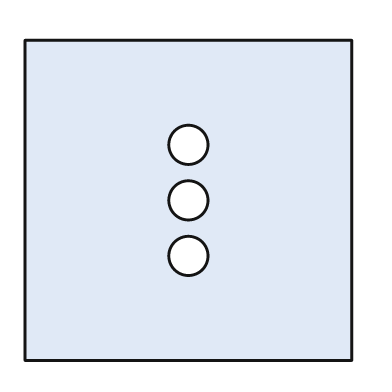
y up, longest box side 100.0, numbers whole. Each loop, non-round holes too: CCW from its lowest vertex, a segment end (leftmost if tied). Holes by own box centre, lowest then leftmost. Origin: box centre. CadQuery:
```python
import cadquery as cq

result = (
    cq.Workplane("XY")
    .moveTo(-50.0, -49.0)
    .lineTo(50.0, -49.0)
    .lineTo(50.0, 49.0)
    .lineTo(-50.0, 49.0)
    .close()
    .moveTo(0.0, -17.0)
    .circle(6.0)
    .moveTo(0.0, 0.0)
    .circle(6.0)
    .moveTo(0.0, 17.0)
    .circle(6.0)
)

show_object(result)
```